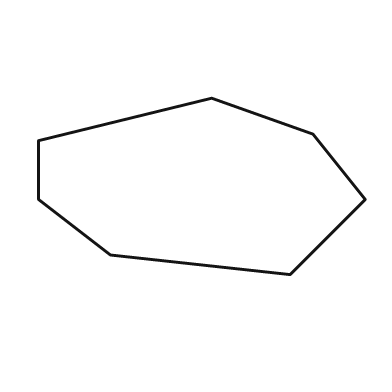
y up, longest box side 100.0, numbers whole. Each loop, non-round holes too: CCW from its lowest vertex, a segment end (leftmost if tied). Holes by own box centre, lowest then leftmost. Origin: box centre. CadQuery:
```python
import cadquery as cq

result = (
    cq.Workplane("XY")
    .moveTo(27.0, -27.0)
    .lineTo(50.0, -4.0)
    .lineTo(34.0, 16.0)
    .lineTo(3.0, 27.0)
    .lineTo(-50.0, 14.0)
    .lineTo(-50.0, -4.0)
    .lineTo(-28.0, -21.0)
    .close()
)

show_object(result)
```